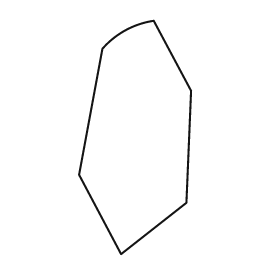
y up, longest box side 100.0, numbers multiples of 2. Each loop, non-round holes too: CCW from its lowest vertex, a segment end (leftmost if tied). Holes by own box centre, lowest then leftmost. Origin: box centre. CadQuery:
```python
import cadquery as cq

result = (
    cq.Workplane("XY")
    .moveTo(-6.0, -50.0)
    .lineTo(22.0, -28.0)
    .lineTo(24.0, 20.0)
    .lineTo(8.0, 50.0)
    .threePointArc((-4.0, 46.0), (-14.0, 38.0))
    .lineTo(-24.0, -16.0)
    .close()
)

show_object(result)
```